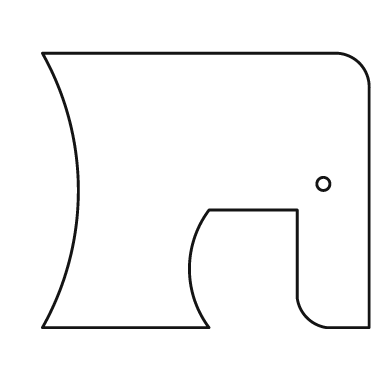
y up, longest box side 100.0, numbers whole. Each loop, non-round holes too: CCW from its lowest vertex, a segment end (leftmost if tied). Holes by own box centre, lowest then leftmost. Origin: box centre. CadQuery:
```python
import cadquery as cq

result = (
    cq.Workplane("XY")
    .moveTo(-50.0, -42.0)
    .lineTo(1.0, -42.0)
    .threePointArc((-5.0, -24.0), (1.0, -6.0))
    .lineTo(28.0, -6.0)
    .lineTo(28.0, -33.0)
    .threePointArc((31.0, -39.0), (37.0, -42.0))
    .lineTo(50.0, -42.0)
    .lineTo(50.0, 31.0)
    .threePointArc((47.0, 39.0), (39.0, 42.0))
    .lineTo(-50.0, 42.0)
    .threePointArc((-39.0, 0.0), (-50.0, -42.0))
    .close()
    .moveTo(36.0, 2.0)
    .circle(2.0)
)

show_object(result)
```